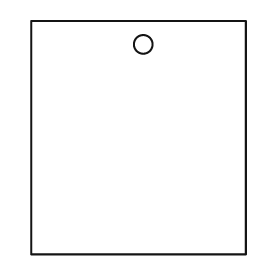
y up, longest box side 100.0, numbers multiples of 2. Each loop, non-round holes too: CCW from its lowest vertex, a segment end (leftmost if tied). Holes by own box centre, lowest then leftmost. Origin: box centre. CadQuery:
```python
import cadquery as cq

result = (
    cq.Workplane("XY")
    .moveTo(-46.0, -50.0)
    .lineTo(46.0, -50.0)
    .lineTo(46.0, 50.0)
    .lineTo(-46.0, 50.0)
    .close()
    .moveTo(2.0, 40.0)
    .circle(4.0)
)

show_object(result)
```